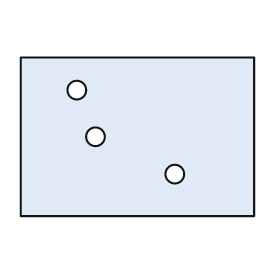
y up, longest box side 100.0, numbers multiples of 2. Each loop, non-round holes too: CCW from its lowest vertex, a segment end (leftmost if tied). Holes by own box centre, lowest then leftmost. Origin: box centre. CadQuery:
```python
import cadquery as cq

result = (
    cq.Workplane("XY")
    .moveTo(-50.0, -34.0)
    .lineTo(50.0, -34.0)
    .lineTo(50.0, 34.0)
    .lineTo(-50.0, 34.0)
    .close()
    .moveTo(16.0, -16.0)
    .circle(4.0)
    .moveTo(-18.0, 0.0)
    .circle(4.0)
    .moveTo(-26.0, 20.0)
    .circle(4.0)
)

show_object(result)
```